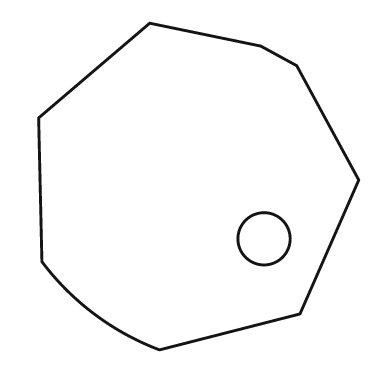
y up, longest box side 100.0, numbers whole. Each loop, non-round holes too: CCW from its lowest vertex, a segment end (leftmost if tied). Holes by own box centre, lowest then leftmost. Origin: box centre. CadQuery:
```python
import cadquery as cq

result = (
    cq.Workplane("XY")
    .moveTo(-12.0, -50.0)
    .lineTo(31.0, -39.0)
    .lineTo(49.0, 2.0)
    .lineTo(30.0, 37.0)
    .lineTo(19.0, 43.0)
    .lineTo(-15.0, 50.0)
    .lineTo(-49.0, 21.0)
    .lineTo(-48.0, -23.0)
    .threePointArc((-32.0, -39.0), (-12.0, -50.0))
    .close()
    .moveTo(20.0, -16.0)
    .circle(8.0)
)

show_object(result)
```